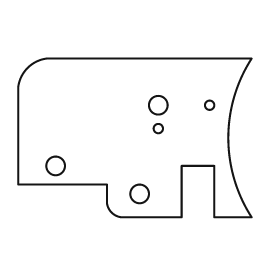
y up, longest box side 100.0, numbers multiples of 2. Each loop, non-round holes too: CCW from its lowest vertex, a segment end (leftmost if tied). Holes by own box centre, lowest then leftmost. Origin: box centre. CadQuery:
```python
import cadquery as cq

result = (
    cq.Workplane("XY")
    .moveTo(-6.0, -34.0)
    .lineTo(20.0, -34.0)
    .lineTo(20.0, -12.0)
    .lineTo(34.0, -12.0)
    .lineTo(34.0, -34.0)
    .lineTo(50.0, -34.0)
    .threePointArc((40.0, 0.0), (50.0, 34.0))
    .lineTo(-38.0, 34.0)
    .threePointArc((-46.0, 30.0), (-50.0, 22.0))
    .lineTo(-50.0, -20.0)
    .lineTo(-12.0, -20.0)
    .lineTo(-12.0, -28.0)
    .threePointArc((-10.0, -32.0), (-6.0, -34.0))
    .close()
    .moveTo(2.0, -24.0)
    .circle(4.0)
    .moveTo(-34.0, -12.0)
    .circle(4.0)
    .moveTo(10.0, 4.0)
    .circle(2.0)
    .moveTo(10.0, 14.0)
    .circle(4.0)
    .moveTo(32.0, 14.0)
    .circle(2.0)
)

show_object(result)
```